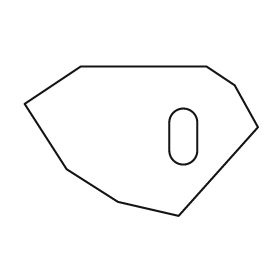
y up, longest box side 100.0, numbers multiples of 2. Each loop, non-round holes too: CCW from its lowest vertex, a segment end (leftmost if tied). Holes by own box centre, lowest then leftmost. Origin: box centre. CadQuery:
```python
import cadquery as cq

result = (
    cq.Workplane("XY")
    .moveTo(16.0, -32.0)
    .lineTo(50.0, 6.0)
    .lineTo(40.0, 24.0)
    .lineTo(28.0, 32.0)
    .lineTo(-26.0, 32.0)
    .lineTo(-50.0, 16.0)
    .lineTo(-32.0, -12.0)
    .lineTo(-10.0, -26.0)
    .close()
    .moveTo(12.0, -4.0)
    .threePointArc((18.0, -10.0), (24.0, -4.0))
    .lineTo(24.0, 8.0)
    .threePointArc((18.0, 14.0), (12.0, 8.0))
    .close()
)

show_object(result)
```